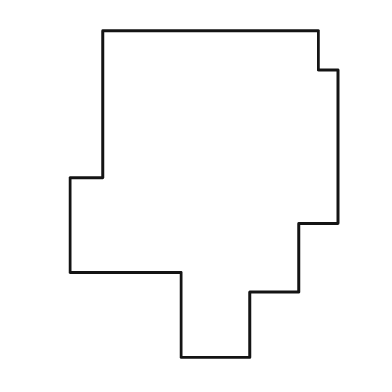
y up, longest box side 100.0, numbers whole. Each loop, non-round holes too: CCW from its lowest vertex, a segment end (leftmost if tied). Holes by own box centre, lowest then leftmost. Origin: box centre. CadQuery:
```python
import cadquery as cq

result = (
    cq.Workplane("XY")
    .moveTo(-7.0, -50.0)
    .lineTo(14.0, -50.0)
    .lineTo(14.0, -30.0)
    .lineTo(29.0, -30.0)
    .lineTo(29.0, -9.0)
    .lineTo(41.0, -9.0)
    .lineTo(41.0, 38.0)
    .lineTo(35.0, 38.0)
    .lineTo(35.0, 50.0)
    .lineTo(-31.0, 50.0)
    .lineTo(-31.0, 5.0)
    .lineTo(-41.0, 5.0)
    .lineTo(-41.0, -24.0)
    .lineTo(-7.0, -24.0)
    .close()
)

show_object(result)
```